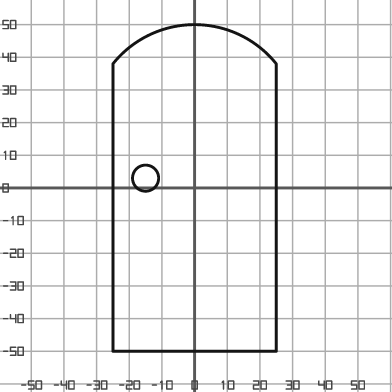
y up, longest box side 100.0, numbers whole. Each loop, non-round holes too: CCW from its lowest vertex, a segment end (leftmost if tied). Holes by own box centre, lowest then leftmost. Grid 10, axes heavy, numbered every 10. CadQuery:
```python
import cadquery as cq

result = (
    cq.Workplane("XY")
    .moveTo(-25.0, -50.0)
    .lineTo(25.0, -50.0)
    .lineTo(25.0, 38.0)
    .threePointArc((0.0, 50.0), (-25.0, 38.0))
    .close()
    .moveTo(-15.0, 3.0)
    .circle(4.0)
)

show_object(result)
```